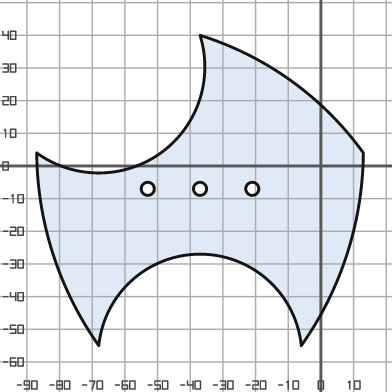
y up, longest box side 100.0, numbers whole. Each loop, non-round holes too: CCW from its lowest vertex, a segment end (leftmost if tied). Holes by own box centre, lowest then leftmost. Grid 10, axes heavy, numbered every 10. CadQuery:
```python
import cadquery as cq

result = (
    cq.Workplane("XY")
    .moveTo(-68.0, -55.0)
    .threePointArc((-37.0, -27.0), (-6.0, -55.0))
    .threePointArc((8.0, -27.0), (13.0, 4.0))
    .threePointArc((-9.0, 26.0), (-37.0, 40.0))
    .threePointArc((-49.0, 4.0), (-87.0, 4.0))
    .threePointArc((-82.0, -27.0), (-68.0, -55.0))
    .close()
    .moveTo(-53.0, -7.0)
    .circle(2.0)
    .moveTo(-37.0, -7.0)
    .circle(2.0)
    .moveTo(-21.0, -7.0)
    .circle(2.0)
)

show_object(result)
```